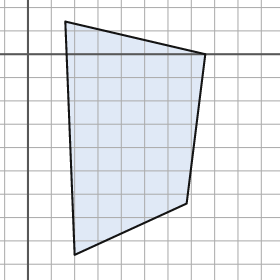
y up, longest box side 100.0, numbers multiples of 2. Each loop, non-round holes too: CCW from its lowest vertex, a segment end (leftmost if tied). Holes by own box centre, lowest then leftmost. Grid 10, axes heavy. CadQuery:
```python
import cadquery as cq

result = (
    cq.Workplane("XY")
    .moveTo(20.0, -86.0)
    .lineTo(68.0, -64.0)
    .lineTo(76.0, 0.0)
    .lineTo(16.0, 14.0)
    .close()
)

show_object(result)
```